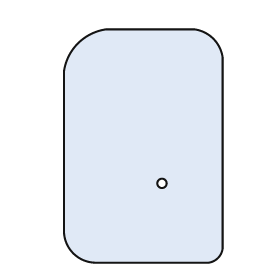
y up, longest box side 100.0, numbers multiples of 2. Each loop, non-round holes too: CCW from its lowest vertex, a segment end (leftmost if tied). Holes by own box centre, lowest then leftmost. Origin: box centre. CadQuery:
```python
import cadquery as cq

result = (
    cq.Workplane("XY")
    .moveTo(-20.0, -50.0)
    .lineTo(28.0, -50.0)
    .threePointArc((32.0, -48.0), (34.0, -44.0))
    .lineTo(34.0, 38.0)
    .threePointArc((30.0, 46.0), (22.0, 50.0))
    .lineTo(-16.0, 50.0)
    .threePointArc((-28.0, 44.0), (-34.0, 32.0))
    .lineTo(-34.0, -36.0)
    .threePointArc((-30.0, -46.0), (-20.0, -50.0))
    .close()
    .moveTo(8.0, -16.0)
    .circle(2.0)
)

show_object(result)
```